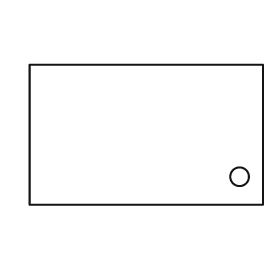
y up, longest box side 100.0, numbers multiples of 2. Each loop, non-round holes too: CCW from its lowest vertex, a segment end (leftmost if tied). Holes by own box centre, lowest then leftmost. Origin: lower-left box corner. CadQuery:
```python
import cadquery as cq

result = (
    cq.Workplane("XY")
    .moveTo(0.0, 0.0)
    .lineTo(100.0, 0.0)
    .lineTo(100.0, 60.0)
    .lineTo(0.0, 60.0)
    .close()
    .moveTo(90.0, 12.0)
    .circle(4.0)
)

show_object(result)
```